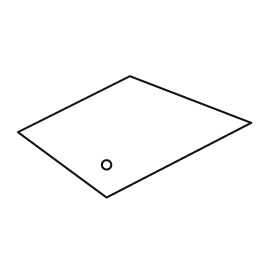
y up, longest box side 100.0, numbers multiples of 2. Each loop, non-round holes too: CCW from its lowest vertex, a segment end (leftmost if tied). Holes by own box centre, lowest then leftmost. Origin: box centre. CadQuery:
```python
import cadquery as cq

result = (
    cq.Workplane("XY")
    .moveTo(-12.0, -26.0)
    .lineTo(50.0, 6.0)
    .lineTo(-2.0, 26.0)
    .lineTo(-50.0, 2.0)
    .close()
    .moveTo(-12.0, -12.0)
    .circle(2.0)
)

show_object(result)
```